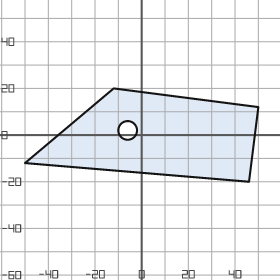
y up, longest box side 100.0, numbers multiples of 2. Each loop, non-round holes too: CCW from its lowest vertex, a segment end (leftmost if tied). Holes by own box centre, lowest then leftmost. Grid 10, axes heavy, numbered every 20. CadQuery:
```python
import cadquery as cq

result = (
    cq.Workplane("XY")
    .moveTo(46.0, -20.0)
    .lineTo(50.0, 12.0)
    .lineTo(-12.0, 20.0)
    .lineTo(-50.0, -12.0)
    .close()
    .moveTo(-6.0, 2.0)
    .circle(4.0)
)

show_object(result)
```